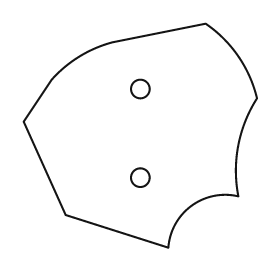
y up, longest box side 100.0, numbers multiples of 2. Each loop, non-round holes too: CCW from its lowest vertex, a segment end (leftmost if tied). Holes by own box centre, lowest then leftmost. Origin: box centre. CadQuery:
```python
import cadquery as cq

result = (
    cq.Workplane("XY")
    .moveTo(12.0, -48.0)
    .threePointArc((22.0, -30.0), (42.0, -26.0))
    .threePointArc((42.0, -4.0), (50.0, 16.0))
    .threePointArc((42.0, 34.0), (28.0, 48.0))
    .lineTo(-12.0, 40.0)
    .threePointArc((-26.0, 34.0), (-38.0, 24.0))
    .lineTo(-50.0, 6.0)
    .lineTo(-32.0, -34.0)
    .close()
    .moveTo(0.0, -18.0)
    .circle(4.0)
    .moveTo(0.0, 20.0)
    .circle(4.0)
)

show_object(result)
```